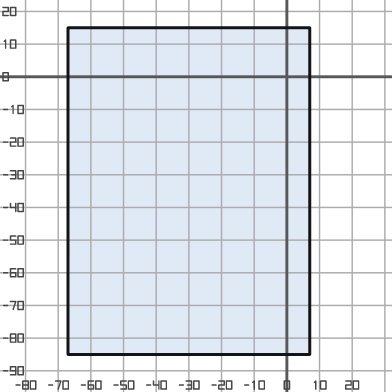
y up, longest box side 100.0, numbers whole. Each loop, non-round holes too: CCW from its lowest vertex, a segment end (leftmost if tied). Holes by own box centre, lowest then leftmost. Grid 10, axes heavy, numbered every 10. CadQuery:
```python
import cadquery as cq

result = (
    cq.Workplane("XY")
    .moveTo(-67.0, -85.0)
    .lineTo(7.0, -85.0)
    .lineTo(7.0, 15.0)
    .lineTo(-67.0, 15.0)
    .close()
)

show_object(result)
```